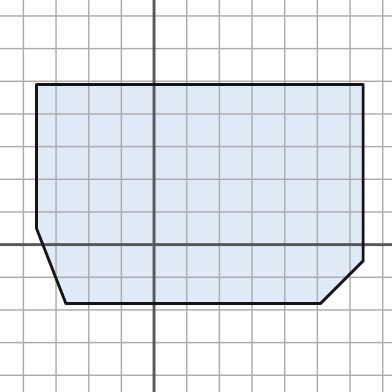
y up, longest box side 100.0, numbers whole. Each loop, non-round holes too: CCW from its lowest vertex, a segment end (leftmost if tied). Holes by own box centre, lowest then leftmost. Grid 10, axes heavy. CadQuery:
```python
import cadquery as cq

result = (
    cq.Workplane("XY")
    .moveTo(-27.0, -18.0)
    .lineTo(51.0, -18.0)
    .lineTo(64.0, -5.0)
    .lineTo(64.0, 49.0)
    .lineTo(-36.0, 49.0)
    .lineTo(-36.0, 5.0)
    .close()
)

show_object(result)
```